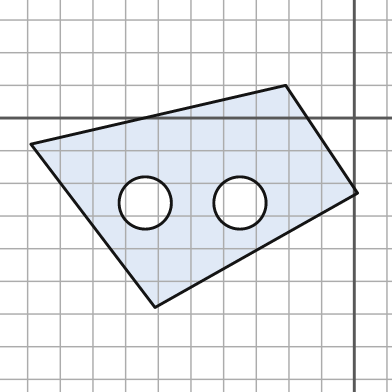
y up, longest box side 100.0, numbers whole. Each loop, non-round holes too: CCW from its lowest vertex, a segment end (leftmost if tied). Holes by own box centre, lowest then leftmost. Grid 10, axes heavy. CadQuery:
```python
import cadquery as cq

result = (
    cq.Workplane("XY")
    .moveTo(-61.0, -58.0)
    .lineTo(1.0, -23.0)
    .lineTo(-21.0, 10.0)
    .lineTo(-99.0, -8.0)
    .close()
    .moveTo(-64.0, -26.0)
    .circle(8.0)
    .moveTo(-35.0, -26.0)
    .circle(8.0)
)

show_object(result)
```